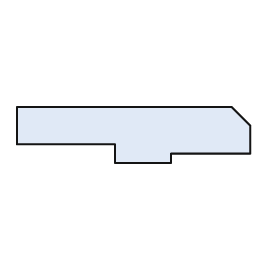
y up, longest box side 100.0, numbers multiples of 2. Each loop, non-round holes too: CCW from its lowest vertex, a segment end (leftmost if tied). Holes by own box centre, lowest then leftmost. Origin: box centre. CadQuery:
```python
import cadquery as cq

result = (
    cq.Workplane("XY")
    .moveTo(-8.0, -12.0)
    .lineTo(16.0, -12.0)
    .lineTo(16.0, -8.0)
    .lineTo(50.0, -8.0)
    .lineTo(50.0, 4.0)
    .lineTo(42.0, 12.0)
    .lineTo(-50.0, 12.0)
    .lineTo(-50.0, -4.0)
    .lineTo(-8.0, -4.0)
    .close()
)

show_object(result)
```